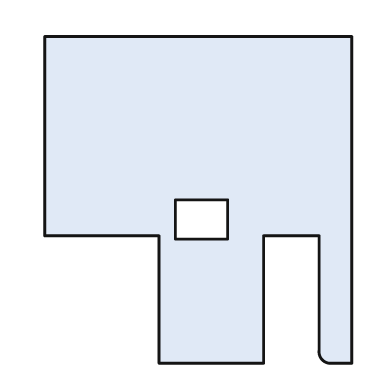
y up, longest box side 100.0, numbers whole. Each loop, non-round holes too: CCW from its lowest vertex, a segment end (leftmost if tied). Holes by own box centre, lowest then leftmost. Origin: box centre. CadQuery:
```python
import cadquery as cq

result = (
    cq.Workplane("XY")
    .moveTo(-12.0, -50.0)
    .lineTo(20.0, -50.0)
    .lineTo(20.0, -11.0)
    .lineTo(37.0, -11.0)
    .lineTo(37.0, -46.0)
    .threePointArc((38.0, -49.0), (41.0, -50.0))
    .lineTo(47.0, -50.0)
    .lineTo(47.0, 50.0)
    .lineTo(-47.0, 50.0)
    .lineTo(-47.0, -11.0)
    .lineTo(-12.0, -11.0)
    .close()
    .moveTo(-7.0, -12.0)
    .lineTo(9.0, -12.0)
    .lineTo(9.0, 0.0)
    .lineTo(-7.0, 0.0)
    .close()
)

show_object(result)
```